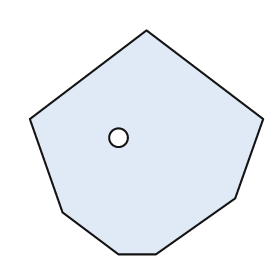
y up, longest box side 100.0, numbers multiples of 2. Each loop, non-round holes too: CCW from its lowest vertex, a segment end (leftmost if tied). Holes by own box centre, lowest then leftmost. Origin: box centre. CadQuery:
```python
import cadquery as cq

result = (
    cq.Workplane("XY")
    .moveTo(-12.0, -48.0)
    .lineTo(4.0, -48.0)
    .lineTo(38.0, -24.0)
    .lineTo(50.0, 10.0)
    .lineTo(0.0, 48.0)
    .lineTo(-50.0, 10.0)
    .lineTo(-36.0, -30.0)
    .close()
    .moveTo(-12.0, 2.0)
    .circle(4.0)
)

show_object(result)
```